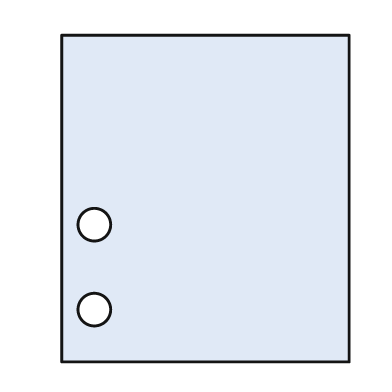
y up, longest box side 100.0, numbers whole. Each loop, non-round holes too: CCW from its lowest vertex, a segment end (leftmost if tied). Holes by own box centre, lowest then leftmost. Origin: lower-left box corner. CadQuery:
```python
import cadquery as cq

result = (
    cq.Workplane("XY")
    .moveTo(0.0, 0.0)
    .lineTo(88.0, 0.0)
    .lineTo(88.0, 100.0)
    .lineTo(0.0, 100.0)
    .close()
    .moveTo(10.0, 16.0)
    .circle(5.0)
    .moveTo(10.0, 42.0)
    .circle(5.0)
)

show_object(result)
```